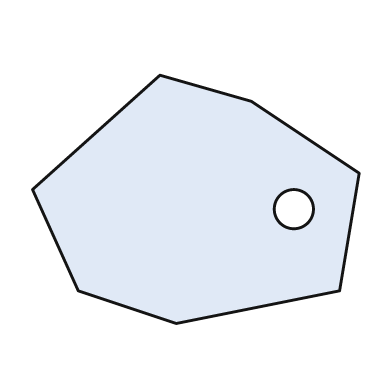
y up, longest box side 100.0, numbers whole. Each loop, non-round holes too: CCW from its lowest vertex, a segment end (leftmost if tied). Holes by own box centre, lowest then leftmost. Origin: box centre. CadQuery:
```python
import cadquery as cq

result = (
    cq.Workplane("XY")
    .moveTo(-6.0, -38.0)
    .lineTo(44.0, -28.0)
    .lineTo(50.0, 8.0)
    .lineTo(17.0, 30.0)
    .lineTo(-11.0, 38.0)
    .lineTo(-50.0, 3.0)
    .lineTo(-36.0, -28.0)
    .close()
    .moveTo(30.0, -3.0)
    .circle(6.0)
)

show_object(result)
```